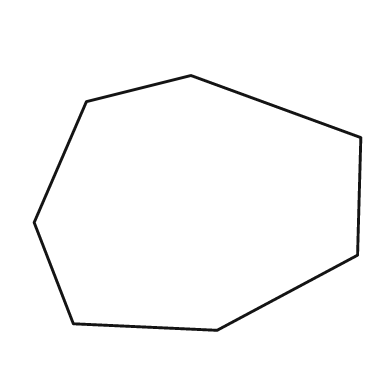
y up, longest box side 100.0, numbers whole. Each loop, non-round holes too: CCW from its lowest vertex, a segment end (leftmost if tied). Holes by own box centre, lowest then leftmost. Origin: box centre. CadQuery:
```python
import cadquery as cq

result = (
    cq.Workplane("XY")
    .moveTo(6.0, -39.0)
    .lineTo(49.0, -16.0)
    .lineTo(50.0, 20.0)
    .lineTo(-2.0, 39.0)
    .lineTo(-34.0, 31.0)
    .lineTo(-50.0, -6.0)
    .lineTo(-38.0, -37.0)
    .close()
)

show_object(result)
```